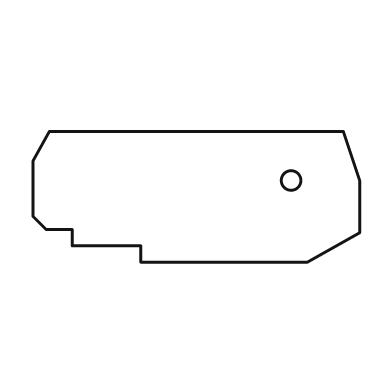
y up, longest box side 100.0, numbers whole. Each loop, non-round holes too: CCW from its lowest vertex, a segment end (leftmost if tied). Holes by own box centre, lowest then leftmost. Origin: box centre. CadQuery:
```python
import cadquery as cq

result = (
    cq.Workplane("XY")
    .moveTo(-17.0, -20.0)
    .lineTo(34.0, -20.0)
    .lineTo(50.0, -11.0)
    .lineTo(50.0, 5.0)
    .lineTo(45.0, 20.0)
    .lineTo(-45.0, 20.0)
    .lineTo(-50.0, 11.0)
    .lineTo(-50.0, -6.0)
    .lineTo(-46.0, -10.0)
    .lineTo(-38.0, -10.0)
    .lineTo(-38.0, -15.0)
    .lineTo(-17.0, -15.0)
    .close()
    .moveTo(29.0, 5.0)
    .circle(3.0)
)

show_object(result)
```